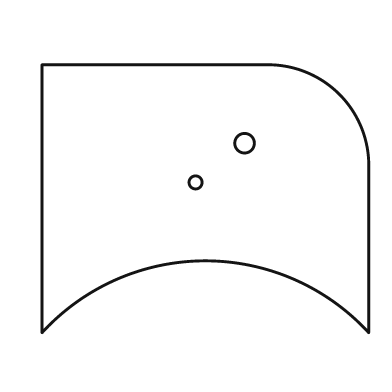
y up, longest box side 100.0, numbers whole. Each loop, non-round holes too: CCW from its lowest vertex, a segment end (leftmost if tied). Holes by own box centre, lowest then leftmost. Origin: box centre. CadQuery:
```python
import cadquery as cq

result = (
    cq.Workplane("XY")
    .moveTo(-50.0, -41.0)
    .threePointArc((0.0, -19.0), (50.0, -41.0))
    .lineTo(50.0, 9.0)
    .threePointArc((41.0, 32.0), (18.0, 41.0))
    .lineTo(-50.0, 41.0)
    .close()
    .moveTo(-3.0, 5.0)
    .circle(2.0)
    .moveTo(12.0, 17.0)
    .circle(3.0)
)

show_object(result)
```